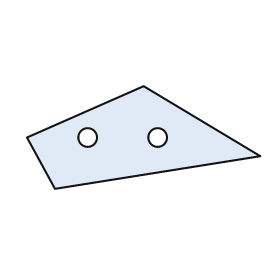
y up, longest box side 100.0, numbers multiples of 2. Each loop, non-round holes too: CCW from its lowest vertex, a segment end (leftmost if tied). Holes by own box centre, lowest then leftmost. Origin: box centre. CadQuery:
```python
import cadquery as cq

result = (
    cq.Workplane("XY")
    .moveTo(-38.0, -22.0)
    .lineTo(50.0, -8.0)
    .lineTo(0.0, 22.0)
    .lineTo(-50.0, 0.0)
    .close()
    .moveTo(-24.0, 0.0)
    .circle(4.0)
    .moveTo(6.0, 0.0)
    .circle(4.0)
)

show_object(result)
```